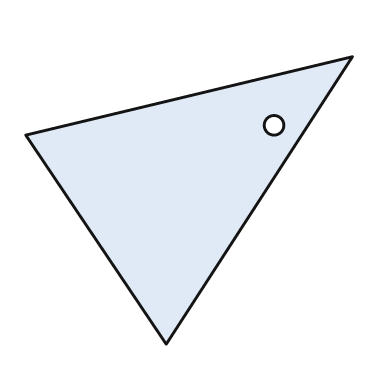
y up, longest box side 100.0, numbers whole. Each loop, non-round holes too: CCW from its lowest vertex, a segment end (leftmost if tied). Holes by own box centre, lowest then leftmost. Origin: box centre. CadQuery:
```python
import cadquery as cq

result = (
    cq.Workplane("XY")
    .moveTo(-7.0, -44.0)
    .lineTo(50.0, 44.0)
    .lineTo(-50.0, 20.0)
    .close()
    .moveTo(26.0, 23.0)
    .circle(3.0)
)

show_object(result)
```